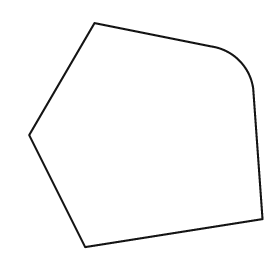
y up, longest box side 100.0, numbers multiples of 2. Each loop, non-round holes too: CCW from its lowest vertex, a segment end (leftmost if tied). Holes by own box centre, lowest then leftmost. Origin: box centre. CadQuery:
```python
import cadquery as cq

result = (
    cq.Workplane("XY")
    .moveTo(-26.0, -48.0)
    .lineTo(50.0, -36.0)
    .lineTo(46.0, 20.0)
    .threePointArc((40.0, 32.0), (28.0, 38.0))
    .lineTo(-22.0, 48.0)
    .lineTo(-50.0, 0.0)
    .close()
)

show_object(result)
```